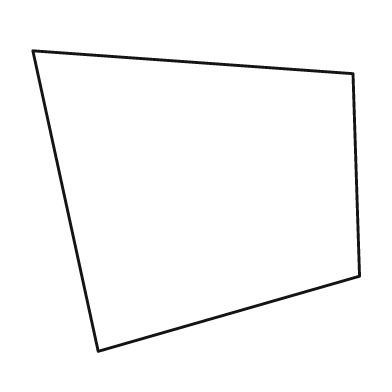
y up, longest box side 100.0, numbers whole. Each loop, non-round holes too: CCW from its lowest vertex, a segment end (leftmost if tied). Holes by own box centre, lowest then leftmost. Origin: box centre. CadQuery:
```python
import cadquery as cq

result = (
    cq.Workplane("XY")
    .moveTo(-30.0, -46.0)
    .lineTo(50.0, -23.0)
    .lineTo(48.0, 39.0)
    .lineTo(-50.0, 46.0)
    .close()
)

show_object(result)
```